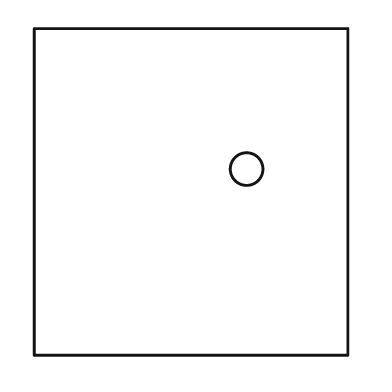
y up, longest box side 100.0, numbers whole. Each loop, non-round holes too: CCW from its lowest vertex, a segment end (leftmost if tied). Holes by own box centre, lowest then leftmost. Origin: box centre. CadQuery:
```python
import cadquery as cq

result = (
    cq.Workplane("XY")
    .moveTo(-48.0, -50.0)
    .lineTo(48.0, -50.0)
    .lineTo(48.0, 50.0)
    .lineTo(-48.0, 50.0)
    .close()
    .moveTo(17.0, 7.0)
    .circle(5.0)
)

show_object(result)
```